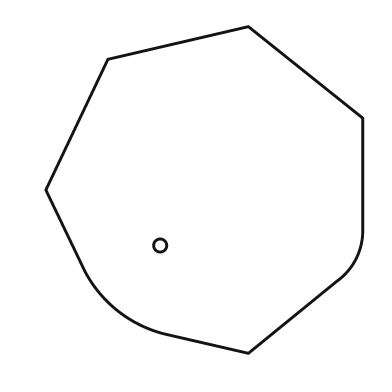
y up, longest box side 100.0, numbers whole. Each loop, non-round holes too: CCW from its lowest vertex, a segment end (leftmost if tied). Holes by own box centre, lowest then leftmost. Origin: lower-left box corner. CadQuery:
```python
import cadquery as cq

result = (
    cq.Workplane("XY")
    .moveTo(62.0, 0.0)
    .lineTo(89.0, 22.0)
    .threePointArc((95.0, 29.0), (97.0, 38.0))
    .lineTo(97.0, 72.0)
    .lineTo(62.0, 100.0)
    .lineTo(19.0, 90.0)
    .lineTo(0.0, 50.0)
    .lineTo(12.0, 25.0)
    .threePointArc((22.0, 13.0), (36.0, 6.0))
    .close()
    .moveTo(35.0, 33.0)
    .circle(2.0)
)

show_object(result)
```